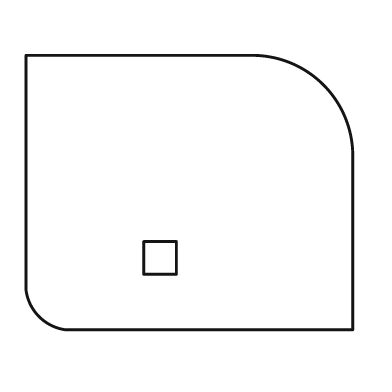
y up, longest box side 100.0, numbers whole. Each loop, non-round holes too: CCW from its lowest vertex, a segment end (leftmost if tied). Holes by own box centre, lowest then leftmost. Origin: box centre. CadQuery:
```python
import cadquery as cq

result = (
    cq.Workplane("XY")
    .moveTo(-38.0, -42.0)
    .lineTo(50.0, -42.0)
    .lineTo(50.0, 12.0)
    .threePointArc((41.0, 33.0), (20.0, 42.0))
    .lineTo(-50.0, 42.0)
    .lineTo(-50.0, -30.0)
    .threePointArc((-46.0, -38.0), (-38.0, -42.0))
    .close()
    .moveTo(-14.0, -25.0)
    .lineTo(-4.0, -25.0)
    .lineTo(-4.0, -15.0)
    .lineTo(-14.0, -15.0)
    .close()
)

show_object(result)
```